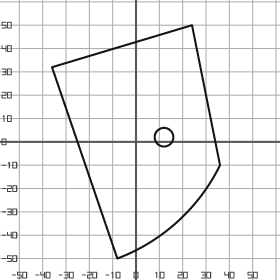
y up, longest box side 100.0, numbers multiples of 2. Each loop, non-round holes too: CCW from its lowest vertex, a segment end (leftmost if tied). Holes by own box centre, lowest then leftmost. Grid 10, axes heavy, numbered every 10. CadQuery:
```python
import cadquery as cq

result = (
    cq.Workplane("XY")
    .moveTo(-8.0, -50.0)
    .threePointArc((18.0, -34.0), (36.0, -10.0))
    .lineTo(24.0, 50.0)
    .lineTo(-36.0, 32.0)
    .close()
    .moveTo(12.0, 2.0)
    .circle(4.0)
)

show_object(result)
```